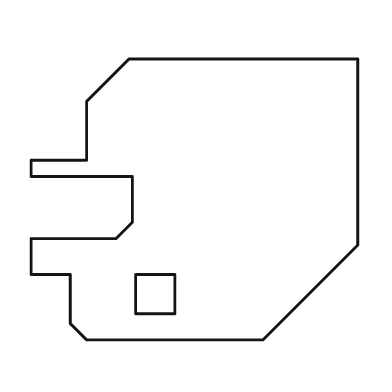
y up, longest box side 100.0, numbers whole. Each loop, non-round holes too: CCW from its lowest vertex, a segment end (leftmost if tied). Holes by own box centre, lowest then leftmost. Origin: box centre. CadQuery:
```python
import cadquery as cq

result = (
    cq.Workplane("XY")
    .moveTo(-33.0, -43.0)
    .lineTo(21.0, -43.0)
    .lineTo(50.0, -14.0)
    .lineTo(50.0, 43.0)
    .lineTo(-20.0, 43.0)
    .lineTo(-33.0, 30.0)
    .lineTo(-33.0, 12.0)
    .lineTo(-50.0, 12.0)
    .lineTo(-50.0, 7.0)
    .lineTo(-19.0, 7.0)
    .lineTo(-19.0, -7.0)
    .lineTo(-24.0, -12.0)
    .lineTo(-50.0, -12.0)
    .lineTo(-50.0, -23.0)
    .lineTo(-38.0, -23.0)
    .lineTo(-38.0, -38.0)
    .close()
    .moveTo(-18.0, -35.0)
    .lineTo(-6.0, -35.0)
    .lineTo(-6.0, -23.0)
    .lineTo(-18.0, -23.0)
    .close()
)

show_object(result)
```